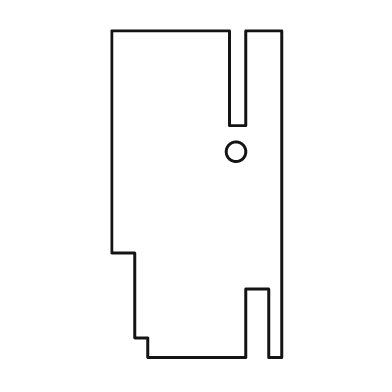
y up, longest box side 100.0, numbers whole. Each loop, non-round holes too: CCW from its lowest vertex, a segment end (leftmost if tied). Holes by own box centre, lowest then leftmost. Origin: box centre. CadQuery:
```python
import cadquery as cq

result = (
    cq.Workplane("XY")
    .moveTo(-15.0, -50.0)
    .lineTo(15.0, -50.0)
    .lineTo(15.0, -29.0)
    .lineTo(22.0, -29.0)
    .lineTo(22.0, -50.0)
    .lineTo(26.0, -50.0)
    .lineTo(26.0, 50.0)
    .lineTo(15.0, 50.0)
    .lineTo(15.0, 21.0)
    .lineTo(10.0, 21.0)
    .lineTo(10.0, 50.0)
    .lineTo(-26.0, 50.0)
    .lineTo(-26.0, -18.0)
    .lineTo(-19.0, -18.0)
    .lineTo(-19.0, -44.0)
    .lineTo(-15.0, -44.0)
    .close()
    .moveTo(12.0, 13.0)
    .circle(3.0)
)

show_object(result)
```